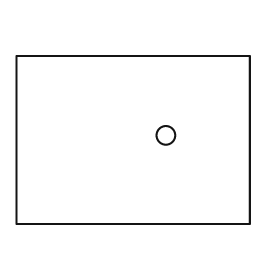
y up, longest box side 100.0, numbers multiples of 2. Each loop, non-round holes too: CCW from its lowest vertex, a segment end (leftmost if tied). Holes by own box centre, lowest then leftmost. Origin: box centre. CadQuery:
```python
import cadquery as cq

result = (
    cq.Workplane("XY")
    .moveTo(-50.0, -36.0)
    .lineTo(50.0, -36.0)
    .lineTo(50.0, 36.0)
    .lineTo(-50.0, 36.0)
    .close()
    .moveTo(14.0, 2.0)
    .circle(4.0)
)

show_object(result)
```